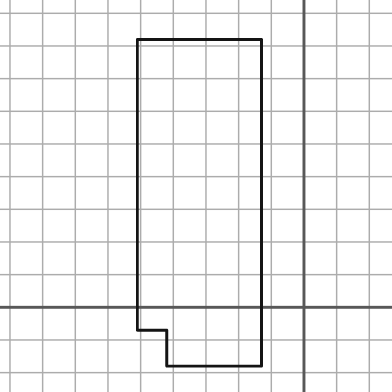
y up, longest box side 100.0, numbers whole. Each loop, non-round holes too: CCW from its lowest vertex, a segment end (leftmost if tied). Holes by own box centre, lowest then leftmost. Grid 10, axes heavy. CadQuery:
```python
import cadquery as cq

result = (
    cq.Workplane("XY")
    .moveTo(-42.0, -18.0)
    .lineTo(-13.0, -18.0)
    .lineTo(-13.0, 82.0)
    .lineTo(-51.0, 82.0)
    .lineTo(-51.0, -7.0)
    .lineTo(-42.0, -7.0)
    .close()
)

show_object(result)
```